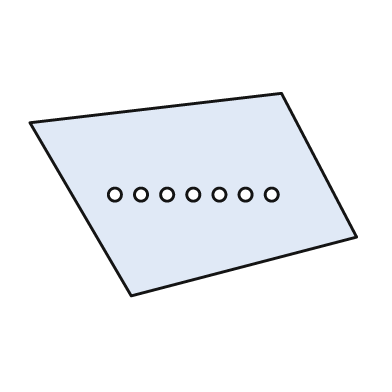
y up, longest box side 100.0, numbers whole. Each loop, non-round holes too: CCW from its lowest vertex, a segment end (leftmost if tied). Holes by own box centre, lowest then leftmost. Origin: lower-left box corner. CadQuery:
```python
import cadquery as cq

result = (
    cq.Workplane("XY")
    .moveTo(31.0, 0.0)
    .lineTo(100.0, 18.0)
    .lineTo(77.0, 62.0)
    .lineTo(0.0, 53.0)
    .close()
    .moveTo(26.0, 31.0)
    .circle(2.0)
    .moveTo(34.0, 31.0)
    .circle(2.0)
    .moveTo(42.0, 31.0)
    .circle(2.0)
    .moveTo(50.0, 31.0)
    .circle(2.0)
    .moveTo(58.0, 31.0)
    .circle(2.0)
    .moveTo(66.0, 31.0)
    .circle(2.0)
    .moveTo(74.0, 31.0)
    .circle(2.0)
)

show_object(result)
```